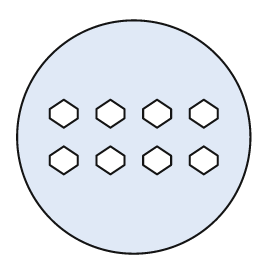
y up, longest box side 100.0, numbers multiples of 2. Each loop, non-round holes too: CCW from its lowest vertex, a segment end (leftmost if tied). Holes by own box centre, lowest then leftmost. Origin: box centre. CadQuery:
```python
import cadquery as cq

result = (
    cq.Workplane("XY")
    .moveTo(0.0, 0.0)
    .circle(50.0)
    .moveTo(-30.0, -16.0)
    .lineTo(-24.0, -12.0)
    .lineTo(-24.0, -8.0)
    .lineTo(-30.0, -4.0)
    .lineTo(-36.0, -8.0)
    .lineTo(-36.0, -12.0)
    .close()
    .moveTo(-10.0, -16.0)
    .lineTo(-4.0, -12.0)
    .lineTo(-4.0, -8.0)
    .lineTo(-10.0, -4.0)
    .lineTo(-16.0, -8.0)
    .lineTo(-16.0, -12.0)
    .close()
    .moveTo(10.0, -16.0)
    .lineTo(16.0, -12.0)
    .lineTo(16.0, -8.0)
    .lineTo(10.0, -4.0)
    .lineTo(4.0, -8.0)
    .lineTo(4.0, -12.0)
    .close()
    .moveTo(30.0, -16.0)
    .lineTo(36.0, -12.0)
    .lineTo(36.0, -8.0)
    .lineTo(30.0, -4.0)
    .lineTo(24.0, -8.0)
    .lineTo(24.0, -12.0)
    .close()
    .moveTo(-30.0, 4.0)
    .lineTo(-24.0, 8.0)
    .lineTo(-24.0, 12.0)
    .lineTo(-30.0, 16.0)
    .lineTo(-36.0, 12.0)
    .lineTo(-36.0, 8.0)
    .close()
    .moveTo(-10.0, 4.0)
    .lineTo(-4.0, 8.0)
    .lineTo(-4.0, 12.0)
    .lineTo(-10.0, 16.0)
    .lineTo(-16.0, 12.0)
    .lineTo(-16.0, 8.0)
    .close()
    .moveTo(10.0, 4.0)
    .lineTo(16.0, 8.0)
    .lineTo(16.0, 12.0)
    .lineTo(10.0, 16.0)
    .lineTo(4.0, 12.0)
    .lineTo(4.0, 8.0)
    .close()
    .moveTo(30.0, 4.0)
    .lineTo(36.0, 8.0)
    .lineTo(36.0, 12.0)
    .lineTo(30.0, 16.0)
    .lineTo(24.0, 12.0)
    .lineTo(24.0, 8.0)
    .close()
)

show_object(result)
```